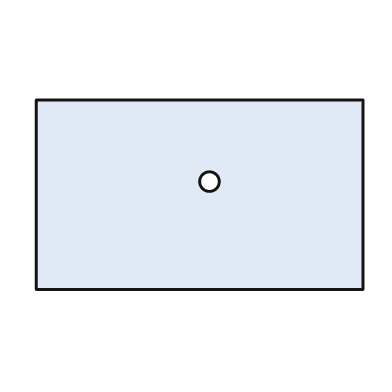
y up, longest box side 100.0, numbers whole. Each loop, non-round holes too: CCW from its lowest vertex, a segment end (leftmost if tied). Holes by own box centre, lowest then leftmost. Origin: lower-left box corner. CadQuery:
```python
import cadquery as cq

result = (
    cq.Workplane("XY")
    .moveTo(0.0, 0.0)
    .lineTo(100.0, 0.0)
    .lineTo(100.0, 58.0)
    .lineTo(0.0, 58.0)
    .close()
    .moveTo(53.0, 33.0)
    .circle(3.0)
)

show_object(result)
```